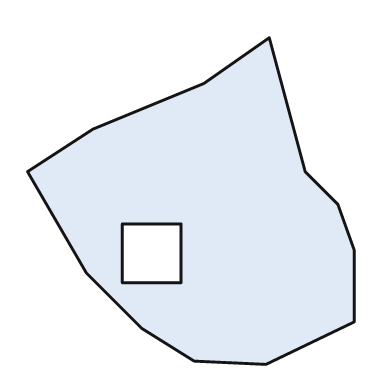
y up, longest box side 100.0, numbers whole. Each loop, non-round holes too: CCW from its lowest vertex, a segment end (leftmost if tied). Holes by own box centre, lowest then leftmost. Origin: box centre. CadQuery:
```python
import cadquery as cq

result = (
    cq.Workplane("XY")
    .moveTo(23.0, -50.0)
    .lineTo(50.0, -37.0)
    .lineTo(50.0, -15.0)
    .lineTo(45.0, -1.0)
    .lineTo(35.0, 9.0)
    .lineTo(24.0, 50.0)
    .lineTo(4.0, 36.0)
    .lineTo(-30.0, 22.0)
    .lineTo(-50.0, 9.0)
    .lineTo(-32.0, -22.0)
    .lineTo(-15.0, -39.0)
    .lineTo(1.0, -49.0)
    .close()
    .moveTo(-21.0, -25.0)
    .lineTo(-3.0, -25.0)
    .lineTo(-3.0, -7.0)
    .lineTo(-21.0, -7.0)
    .close()
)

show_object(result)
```